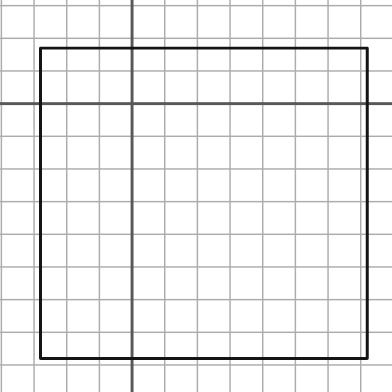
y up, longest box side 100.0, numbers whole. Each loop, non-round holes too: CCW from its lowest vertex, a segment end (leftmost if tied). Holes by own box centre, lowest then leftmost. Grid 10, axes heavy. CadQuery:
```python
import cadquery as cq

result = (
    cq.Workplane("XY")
    .moveTo(-28.0, -78.0)
    .lineTo(72.0, -78.0)
    .lineTo(72.0, 17.0)
    .lineTo(-28.0, 17.0)
    .close()
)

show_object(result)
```